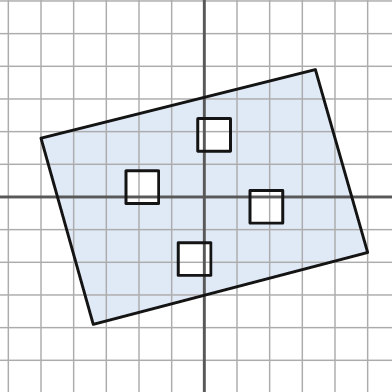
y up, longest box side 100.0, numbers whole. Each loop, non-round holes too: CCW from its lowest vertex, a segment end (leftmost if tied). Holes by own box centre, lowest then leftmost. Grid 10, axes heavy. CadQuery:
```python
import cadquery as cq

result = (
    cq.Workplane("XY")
    .moveTo(-34.0, -39.0)
    .lineTo(50.0, -17.0)
    .lineTo(34.0, 39.0)
    .lineTo(-50.0, 18.0)
    .close()
    .moveTo(-8.0, -24.0)
    .lineTo(2.0, -24.0)
    .lineTo(2.0, -14.0)
    .lineTo(-8.0, -14.0)
    .close()
    .moveTo(14.0, -8.0)
    .lineTo(24.0, -8.0)
    .lineTo(24.0, 2.0)
    .lineTo(14.0, 2.0)
    .close()
    .moveTo(-24.0, -2.0)
    .lineTo(-14.0, -2.0)
    .lineTo(-14.0, 8.0)
    .lineTo(-24.0, 8.0)
    .close()
    .moveTo(-2.0, 14.0)
    .lineTo(8.0, 14.0)
    .lineTo(8.0, 24.0)
    .lineTo(-2.0, 24.0)
    .close()
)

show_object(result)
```